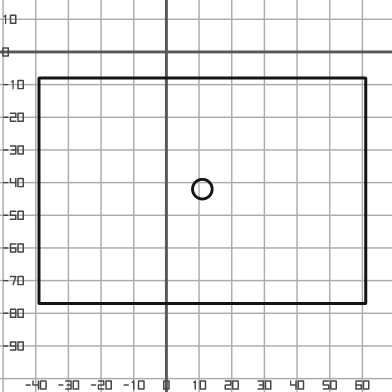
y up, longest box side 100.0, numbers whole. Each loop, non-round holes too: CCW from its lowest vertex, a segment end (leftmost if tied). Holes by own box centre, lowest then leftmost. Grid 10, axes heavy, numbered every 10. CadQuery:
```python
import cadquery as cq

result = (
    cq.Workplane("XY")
    .moveTo(-39.0, -77.0)
    .lineTo(61.0, -77.0)
    .lineTo(61.0, -8.0)
    .lineTo(-39.0, -8.0)
    .close()
    .moveTo(11.0, -42.0)
    .circle(3.0)
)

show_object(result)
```